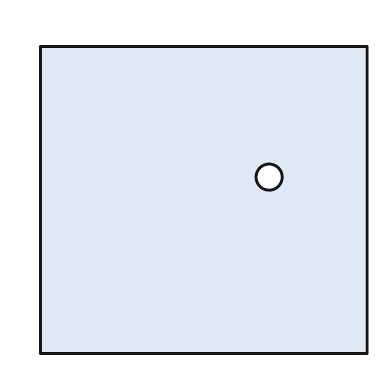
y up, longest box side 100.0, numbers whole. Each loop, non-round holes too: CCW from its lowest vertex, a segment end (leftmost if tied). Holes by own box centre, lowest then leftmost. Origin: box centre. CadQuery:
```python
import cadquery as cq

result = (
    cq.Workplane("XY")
    .moveTo(-50.0, -47.0)
    .lineTo(50.0, -47.0)
    .lineTo(50.0, 47.0)
    .lineTo(-50.0, 47.0)
    .close()
    .moveTo(20.0, 7.0)
    .circle(4.0)
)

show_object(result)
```